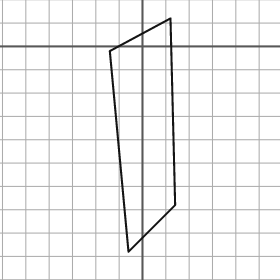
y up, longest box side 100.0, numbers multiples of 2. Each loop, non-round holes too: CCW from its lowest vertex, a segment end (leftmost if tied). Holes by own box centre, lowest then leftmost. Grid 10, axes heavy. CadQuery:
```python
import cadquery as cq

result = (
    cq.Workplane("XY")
    .moveTo(-6.0, -88.0)
    .lineTo(14.0, -68.0)
    .lineTo(12.0, 12.0)
    .lineTo(-14.0, -2.0)
    .close()
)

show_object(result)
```